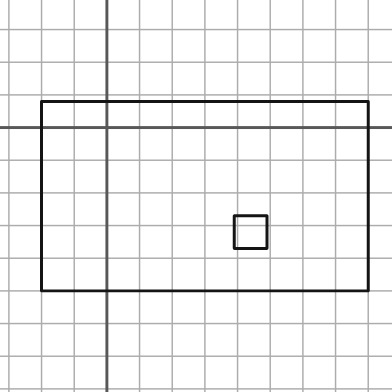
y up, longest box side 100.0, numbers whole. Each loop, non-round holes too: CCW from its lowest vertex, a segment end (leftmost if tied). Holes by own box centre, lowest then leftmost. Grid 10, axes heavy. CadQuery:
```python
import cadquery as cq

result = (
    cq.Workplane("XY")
    .moveTo(-20.0, -50.0)
    .lineTo(80.0, -50.0)
    .lineTo(80.0, 8.0)
    .lineTo(-20.0, 8.0)
    .close()
    .moveTo(39.0, -37.0)
    .lineTo(49.0, -37.0)
    .lineTo(49.0, -27.0)
    .lineTo(39.0, -27.0)
    .close()
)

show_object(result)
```